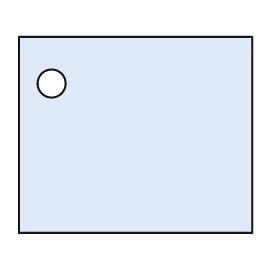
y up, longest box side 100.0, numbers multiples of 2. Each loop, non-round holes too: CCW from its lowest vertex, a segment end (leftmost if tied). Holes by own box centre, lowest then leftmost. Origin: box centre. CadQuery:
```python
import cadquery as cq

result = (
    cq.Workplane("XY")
    .moveTo(-50.0, -42.0)
    .lineTo(50.0, -42.0)
    .lineTo(50.0, 42.0)
    .lineTo(-50.0, 42.0)
    .close()
    .moveTo(-36.0, 22.0)
    .circle(6.0)
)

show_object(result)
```